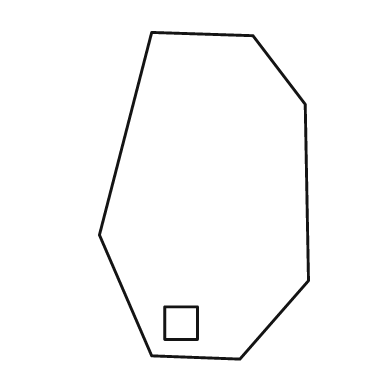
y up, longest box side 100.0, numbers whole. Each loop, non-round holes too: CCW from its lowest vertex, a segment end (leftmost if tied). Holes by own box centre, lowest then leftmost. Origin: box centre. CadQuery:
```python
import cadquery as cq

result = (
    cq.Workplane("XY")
    .moveTo(11.0, -50.0)
    .lineTo(32.0, -26.0)
    .lineTo(31.0, 28.0)
    .lineTo(15.0, 49.0)
    .lineTo(-16.0, 50.0)
    .lineTo(-32.0, -12.0)
    .lineTo(-16.0, -49.0)
    .close()
    .moveTo(-12.0, -44.0)
    .lineTo(-2.0, -44.0)
    .lineTo(-2.0, -34.0)
    .lineTo(-12.0, -34.0)
    .close()
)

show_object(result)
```